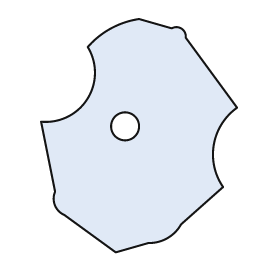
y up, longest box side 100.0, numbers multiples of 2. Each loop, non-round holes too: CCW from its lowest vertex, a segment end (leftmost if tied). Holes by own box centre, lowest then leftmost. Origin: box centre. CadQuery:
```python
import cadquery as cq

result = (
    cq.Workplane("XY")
    .moveTo(-10.0, -50.0)
    .lineTo(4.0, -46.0)
    .threePointArc((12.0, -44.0), (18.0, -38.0))
    .lineTo(36.0, -22.0)
    .threePointArc((32.0, -4.0), (42.0, 12.0))
    .lineTo(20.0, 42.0)
    .threePointArc((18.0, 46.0), (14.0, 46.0))
    .lineTo(0.0, 50.0)
    .threePointArc((-12.0, 46.0), (-22.0, 38.0))
    .threePointArc((-22.0, 16.0), (-42.0, 6.0))
    .lineTo(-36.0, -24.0)
    .threePointArc((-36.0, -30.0), (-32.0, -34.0))
    .close()
    .moveTo(-6.0, 4.0)
    .circle(6.0)
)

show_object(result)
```